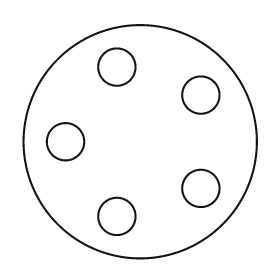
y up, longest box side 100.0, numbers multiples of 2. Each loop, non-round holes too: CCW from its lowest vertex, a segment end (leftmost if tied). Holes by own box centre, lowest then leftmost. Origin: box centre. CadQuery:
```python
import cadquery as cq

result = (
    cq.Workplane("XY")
    .moveTo(0.0, 0.0)
    .circle(50.0)
    .moveTo(-10.0, -32.0)
    .circle(8.0)
    .moveTo(26.0, -20.0)
    .circle(8.0)
    .moveTo(-32.0, 0.0)
    .circle(8.0)
    .moveTo(26.0, 20.0)
    .circle(8.0)
    .moveTo(-10.0, 32.0)
    .circle(8.0)
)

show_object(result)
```